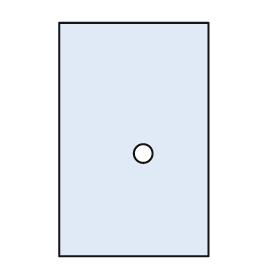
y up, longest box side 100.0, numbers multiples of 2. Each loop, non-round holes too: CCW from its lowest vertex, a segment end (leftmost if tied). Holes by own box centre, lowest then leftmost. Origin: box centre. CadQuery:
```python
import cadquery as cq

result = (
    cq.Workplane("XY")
    .moveTo(-32.0, -50.0)
    .lineTo(32.0, -50.0)
    .lineTo(32.0, 50.0)
    .lineTo(-32.0, 50.0)
    .close()
    .moveTo(4.0, -6.0)
    .circle(4.0)
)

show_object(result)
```